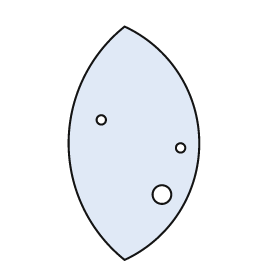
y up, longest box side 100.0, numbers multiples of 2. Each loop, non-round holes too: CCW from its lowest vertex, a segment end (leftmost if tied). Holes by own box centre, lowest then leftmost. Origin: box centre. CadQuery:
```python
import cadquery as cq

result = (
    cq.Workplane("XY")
    .moveTo(-4.0, -50.0)
    .threePointArc((28.0, 0.0), (-4.0, 50.0))
    .threePointArc((-28.0, 0.0), (-4.0, -50.0))
    .close()
    .moveTo(12.0, -22.0)
    .circle(4.0)
    .moveTo(20.0, -2.0)
    .circle(2.0)
    .moveTo(-14.0, 10.0)
    .circle(2.0)
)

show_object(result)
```